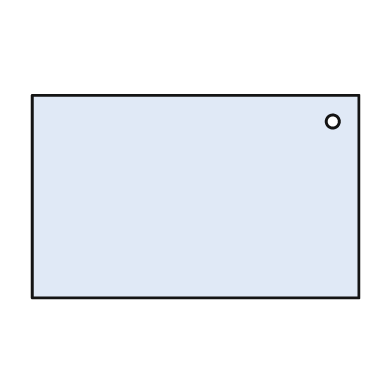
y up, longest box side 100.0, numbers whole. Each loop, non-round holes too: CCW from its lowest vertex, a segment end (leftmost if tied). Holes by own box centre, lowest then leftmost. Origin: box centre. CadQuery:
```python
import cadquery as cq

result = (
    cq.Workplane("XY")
    .moveTo(-50.0, -31.0)
    .lineTo(50.0, -31.0)
    .lineTo(50.0, 31.0)
    .lineTo(-50.0, 31.0)
    .close()
    .moveTo(42.0, 23.0)
    .circle(2.0)
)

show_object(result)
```